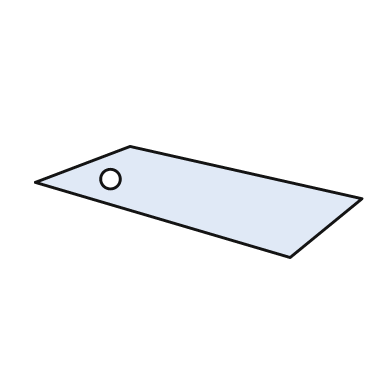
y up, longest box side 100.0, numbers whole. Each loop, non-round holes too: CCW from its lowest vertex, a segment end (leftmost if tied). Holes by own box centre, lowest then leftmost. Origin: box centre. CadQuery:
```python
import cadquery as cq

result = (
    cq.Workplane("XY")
    .moveTo(28.0, -17.0)
    .lineTo(50.0, 1.0)
    .lineTo(-21.0, 17.0)
    .lineTo(-50.0, 6.0)
    .close()
    .moveTo(-27.0, 7.0)
    .circle(3.0)
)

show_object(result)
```